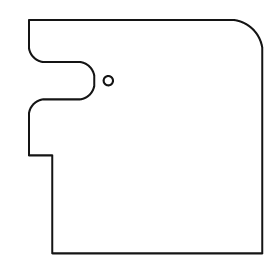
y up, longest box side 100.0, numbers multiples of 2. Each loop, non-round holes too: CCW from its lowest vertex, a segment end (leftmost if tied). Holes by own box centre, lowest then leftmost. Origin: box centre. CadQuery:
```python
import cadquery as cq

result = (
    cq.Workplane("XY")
    .moveTo(-40.0, -50.0)
    .lineTo(50.0, -50.0)
    .lineTo(50.0, 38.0)
    .threePointArc((46.0, 46.0), (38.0, 50.0))
    .lineTo(-50.0, 50.0)
    .lineTo(-50.0, 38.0)
    .threePointArc((-48.0, 34.0), (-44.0, 32.0))
    .lineTo(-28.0, 32.0)
    .threePointArc((-24.0, 30.0), (-22.0, 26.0))
    .lineTo(-22.0, 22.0)
    .threePointArc((-24.0, 18.0), (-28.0, 16.0))
    .lineTo(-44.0, 16.0)
    .threePointArc((-48.0, 14.0), (-50.0, 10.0))
    .lineTo(-50.0, -8.0)
    .lineTo(-40.0, -8.0)
    .close()
    .moveTo(-16.0, 24.0)
    .circle(2.0)
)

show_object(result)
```